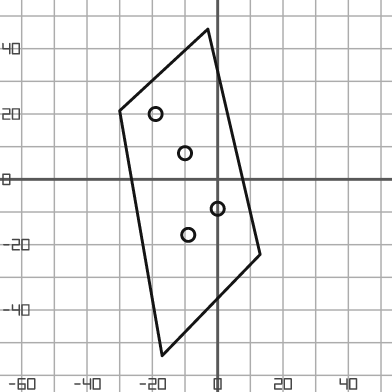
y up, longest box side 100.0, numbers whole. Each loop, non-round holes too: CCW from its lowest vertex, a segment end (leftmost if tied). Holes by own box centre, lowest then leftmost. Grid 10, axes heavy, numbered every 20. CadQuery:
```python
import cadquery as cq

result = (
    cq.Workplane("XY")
    .moveTo(-17.0, -54.0)
    .lineTo(13.0, -23.0)
    .lineTo(-3.0, 46.0)
    .lineTo(-30.0, 21.0)
    .close()
    .moveTo(-9.0, -17.0)
    .circle(2.0)
    .moveTo(0.0, -9.0)
    .circle(2.0)
    .moveTo(-10.0, 8.0)
    .circle(2.0)
    .moveTo(-19.0, 20.0)
    .circle(2.0)
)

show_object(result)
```